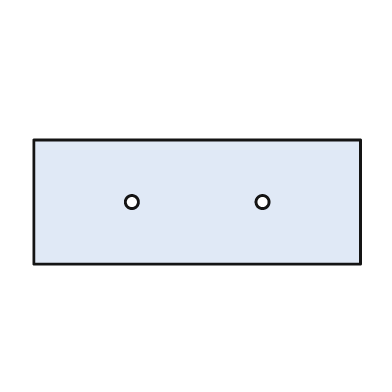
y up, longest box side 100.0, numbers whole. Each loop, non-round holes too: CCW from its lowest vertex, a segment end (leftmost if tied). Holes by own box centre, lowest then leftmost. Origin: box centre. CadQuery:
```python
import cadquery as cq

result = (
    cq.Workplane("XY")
    .moveTo(-50.0, -19.0)
    .lineTo(50.0, -19.0)
    .lineTo(50.0, 19.0)
    .lineTo(-50.0, 19.0)
    .close()
    .moveTo(-20.0, 0.0)
    .circle(2.0)
    .moveTo(20.0, 0.0)
    .circle(2.0)
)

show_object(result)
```